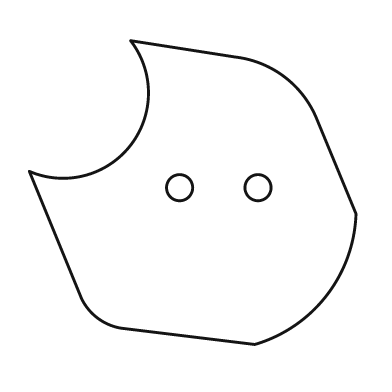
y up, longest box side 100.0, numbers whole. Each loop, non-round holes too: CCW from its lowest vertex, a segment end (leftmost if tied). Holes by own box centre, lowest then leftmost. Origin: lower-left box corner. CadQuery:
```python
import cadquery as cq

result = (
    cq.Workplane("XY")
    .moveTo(69.0, 0.0)
    .threePointArc((91.0, 15.0), (100.0, 40.0))
    .lineTo(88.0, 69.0)
    .threePointArc((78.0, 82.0), (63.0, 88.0))
    .lineTo(31.0, 93.0)
    .threePointArc((31.0, 61.0), (0.0, 53.0))
    .lineTo(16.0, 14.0)
    .threePointArc((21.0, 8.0), (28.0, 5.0))
    .close()
    .moveTo(46.0, 48.0)
    .circle(4.0)
    .moveTo(70.0, 48.0)
    .circle(4.0)
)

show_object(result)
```